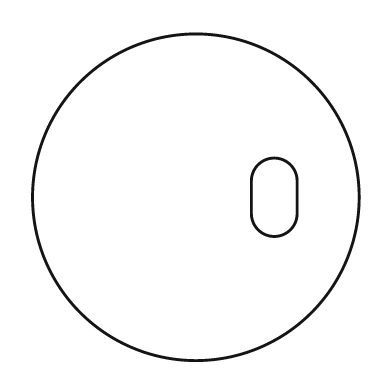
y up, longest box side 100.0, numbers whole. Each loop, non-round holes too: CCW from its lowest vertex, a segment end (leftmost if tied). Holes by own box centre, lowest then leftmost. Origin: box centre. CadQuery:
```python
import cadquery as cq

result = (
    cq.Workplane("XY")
    .moveTo(0.0, 0.0)
    .circle(50.0)
    .moveTo(17.0, -5.0)
    .threePointArc((24.0, -12.0), (31.0, -5.0))
    .lineTo(31.0, 5.0)
    .threePointArc((24.0, 12.0), (17.0, 5.0))
    .close()
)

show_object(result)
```